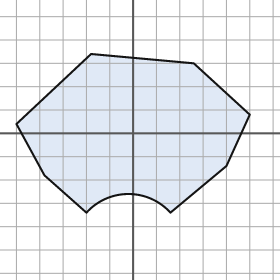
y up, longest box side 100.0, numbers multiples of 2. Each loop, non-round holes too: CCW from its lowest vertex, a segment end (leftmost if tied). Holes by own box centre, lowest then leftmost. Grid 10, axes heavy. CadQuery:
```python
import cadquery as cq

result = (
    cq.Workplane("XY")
    .moveTo(-20.0, -34.0)
    .threePointArc((-2.0, -26.0), (16.0, -34.0))
    .lineTo(40.0, -14.0)
    .lineTo(50.0, 8.0)
    .lineTo(26.0, 30.0)
    .lineTo(-18.0, 34.0)
    .lineTo(-50.0, 4.0)
    .lineTo(-38.0, -18.0)
    .close()
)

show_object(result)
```